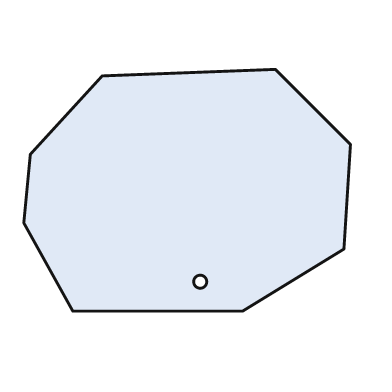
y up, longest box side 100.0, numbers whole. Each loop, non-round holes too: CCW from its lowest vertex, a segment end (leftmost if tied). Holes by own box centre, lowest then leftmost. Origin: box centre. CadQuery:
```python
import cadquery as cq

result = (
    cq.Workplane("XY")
    .moveTo(-35.0, -37.0)
    .lineTo(17.0, -37.0)
    .lineTo(48.0, -18.0)
    .lineTo(50.0, 14.0)
    .lineTo(27.0, 37.0)
    .lineTo(-26.0, 35.0)
    .lineTo(-48.0, 11.0)
    .lineTo(-50.0, -10.0)
    .close()
    .moveTo(4.0, -28.0)
    .circle(2.0)
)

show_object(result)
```